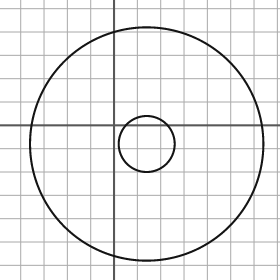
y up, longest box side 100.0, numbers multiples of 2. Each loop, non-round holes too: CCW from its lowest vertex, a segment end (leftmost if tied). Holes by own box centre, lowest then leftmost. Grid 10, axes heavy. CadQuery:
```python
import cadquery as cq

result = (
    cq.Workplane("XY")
    .moveTo(14.0, -8.0)
    .circle(50.0)
    .moveTo(14.0, -8.0)
    .circle(12.0)
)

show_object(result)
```